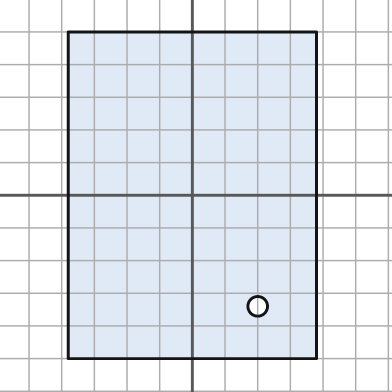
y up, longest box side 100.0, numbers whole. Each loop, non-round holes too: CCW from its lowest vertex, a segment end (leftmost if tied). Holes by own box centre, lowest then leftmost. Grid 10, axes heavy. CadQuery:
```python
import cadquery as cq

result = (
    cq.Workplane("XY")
    .moveTo(-38.0, -50.0)
    .lineTo(38.0, -50.0)
    .lineTo(38.0, 50.0)
    .lineTo(-38.0, 50.0)
    .close()
    .moveTo(20.0, -34.0)
    .circle(3.0)
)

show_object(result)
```